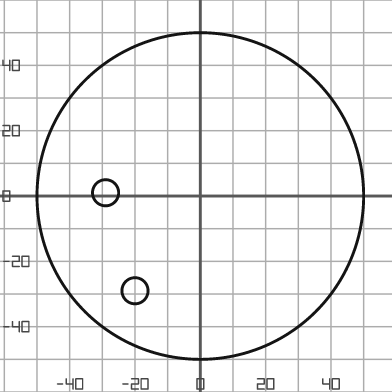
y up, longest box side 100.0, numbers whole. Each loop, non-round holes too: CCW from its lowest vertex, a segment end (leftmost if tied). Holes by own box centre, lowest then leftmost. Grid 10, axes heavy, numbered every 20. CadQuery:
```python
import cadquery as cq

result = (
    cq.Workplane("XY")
    .moveTo(0.0, 0.0)
    .circle(50.0)
    .moveTo(-20.0, -29.0)
    .circle(4.0)
    .moveTo(-29.0, 1.0)
    .circle(4.0)
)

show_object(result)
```